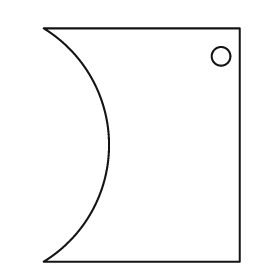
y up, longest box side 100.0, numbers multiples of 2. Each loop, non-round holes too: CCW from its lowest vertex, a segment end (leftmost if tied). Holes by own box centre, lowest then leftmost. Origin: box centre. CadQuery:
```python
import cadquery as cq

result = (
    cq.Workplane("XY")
    .moveTo(-42.0, -50.0)
    .lineTo(42.0, -50.0)
    .lineTo(42.0, 50.0)
    .lineTo(-42.0, 50.0)
    .threePointArc((-14.0, 0.0), (-42.0, -50.0))
    .close()
    .moveTo(34.0, 38.0)
    .circle(4.0)
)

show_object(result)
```